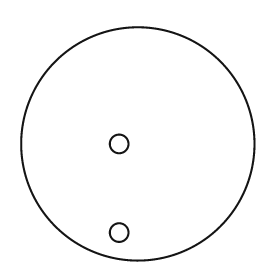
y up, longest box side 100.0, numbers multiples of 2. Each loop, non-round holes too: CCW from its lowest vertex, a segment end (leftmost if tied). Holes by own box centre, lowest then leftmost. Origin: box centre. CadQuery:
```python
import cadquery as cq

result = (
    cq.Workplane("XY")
    .moveTo(0.0, 0.0)
    .circle(50.0)
    .moveTo(-8.0, -38.0)
    .circle(4.0)
    .moveTo(-8.0, 0.0)
    .circle(4.0)
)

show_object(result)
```